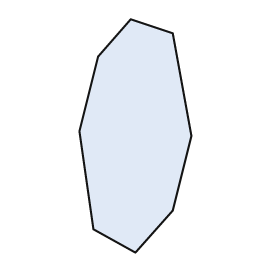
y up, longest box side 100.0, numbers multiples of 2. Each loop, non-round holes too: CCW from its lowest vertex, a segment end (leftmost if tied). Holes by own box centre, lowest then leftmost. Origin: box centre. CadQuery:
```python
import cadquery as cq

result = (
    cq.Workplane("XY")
    .moveTo(0.0, -50.0)
    .lineTo(16.0, -32.0)
    .lineTo(24.0, 0.0)
    .lineTo(16.0, 44.0)
    .lineTo(-2.0, 50.0)
    .lineTo(-16.0, 34.0)
    .lineTo(-24.0, 2.0)
    .lineTo(-18.0, -40.0)
    .close()
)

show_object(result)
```